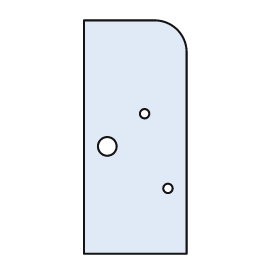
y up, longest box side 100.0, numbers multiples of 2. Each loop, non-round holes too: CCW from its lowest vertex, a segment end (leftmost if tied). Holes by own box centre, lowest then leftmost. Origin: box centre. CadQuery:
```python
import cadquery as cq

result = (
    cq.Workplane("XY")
    .moveTo(-22.0, -50.0)
    .lineTo(22.0, -50.0)
    .lineTo(22.0, 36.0)
    .threePointArc((18.0, 46.0), (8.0, 50.0))
    .lineTo(-22.0, 50.0)
    .close()
    .moveTo(14.0, -22.0)
    .circle(2.0)
    .moveTo(-12.0, -4.0)
    .circle(4.0)
    .moveTo(4.0, 10.0)
    .circle(2.0)
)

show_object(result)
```